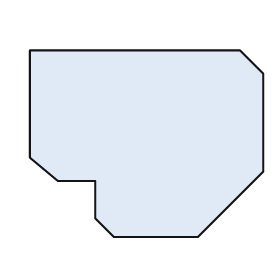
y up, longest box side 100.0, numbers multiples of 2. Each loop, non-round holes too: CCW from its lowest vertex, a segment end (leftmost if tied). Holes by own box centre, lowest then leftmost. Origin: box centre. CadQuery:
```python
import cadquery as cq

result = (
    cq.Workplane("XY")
    .moveTo(-14.0, -40.0)
    .lineTo(22.0, -40.0)
    .lineTo(50.0, -12.0)
    .lineTo(50.0, 30.0)
    .lineTo(40.0, 40.0)
    .lineTo(-50.0, 40.0)
    .lineTo(-50.0, -6.0)
    .lineTo(-38.0, -16.0)
    .lineTo(-22.0, -16.0)
    .lineTo(-22.0, -32.0)
    .close()
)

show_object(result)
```